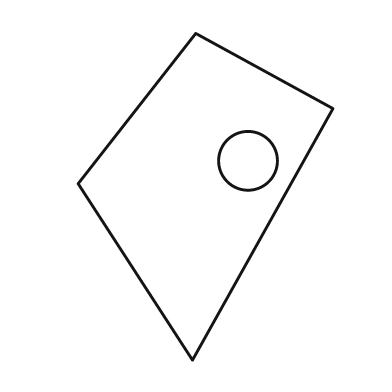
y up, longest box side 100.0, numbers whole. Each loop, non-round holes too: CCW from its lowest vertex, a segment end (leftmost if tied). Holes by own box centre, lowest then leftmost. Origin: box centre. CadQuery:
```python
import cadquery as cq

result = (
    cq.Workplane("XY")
    .moveTo(-4.0, -50.0)
    .lineTo(39.0, 27.0)
    .lineTo(-3.0, 50.0)
    .lineTo(-39.0, 4.0)
    .close()
    .moveTo(13.0, 11.0)
    .circle(9.0)
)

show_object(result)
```